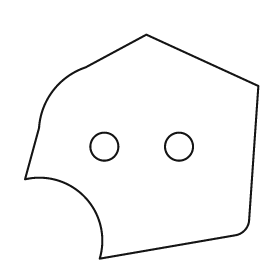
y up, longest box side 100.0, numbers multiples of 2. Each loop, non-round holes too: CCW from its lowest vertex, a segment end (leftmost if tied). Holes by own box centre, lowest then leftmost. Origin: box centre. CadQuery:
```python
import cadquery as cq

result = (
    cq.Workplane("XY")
    .moveTo(-18.0, -48.0)
    .lineTo(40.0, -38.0)
    .threePointArc((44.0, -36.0), (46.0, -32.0))
    .lineTo(50.0, 26.0)
    .lineTo(2.0, 48.0)
    .lineTo(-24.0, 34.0)
    .threePointArc((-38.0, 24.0), (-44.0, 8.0))
    .lineTo(-50.0, -14.0)
    .threePointArc((-24.0, -22.0), (-18.0, -48.0))
    .close()
    .moveTo(-16.0, 0.0)
    .circle(6.0)
    .moveTo(16.0, 0.0)
    .circle(6.0)
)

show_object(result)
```